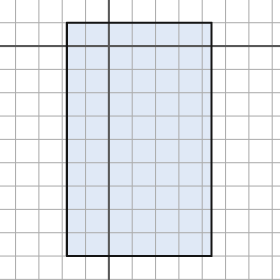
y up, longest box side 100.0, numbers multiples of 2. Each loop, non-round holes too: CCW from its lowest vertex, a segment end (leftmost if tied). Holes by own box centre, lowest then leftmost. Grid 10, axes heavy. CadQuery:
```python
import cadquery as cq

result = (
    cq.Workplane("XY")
    .moveTo(-18.0, -90.0)
    .lineTo(44.0, -90.0)
    .lineTo(44.0, 10.0)
    .lineTo(-18.0, 10.0)
    .close()
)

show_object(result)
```